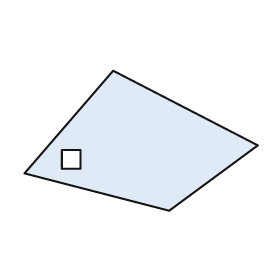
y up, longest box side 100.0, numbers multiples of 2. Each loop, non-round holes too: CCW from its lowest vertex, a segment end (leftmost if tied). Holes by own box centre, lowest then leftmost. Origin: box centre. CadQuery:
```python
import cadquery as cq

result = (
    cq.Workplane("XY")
    .moveTo(12.0, -30.0)
    .lineTo(50.0, -2.0)
    .lineTo(-12.0, 30.0)
    .lineTo(-50.0, -14.0)
    .close()
    .moveTo(-34.0, -12.0)
    .lineTo(-26.0, -12.0)
    .lineTo(-26.0, -4.0)
    .lineTo(-34.0, -4.0)
    .close()
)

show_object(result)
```